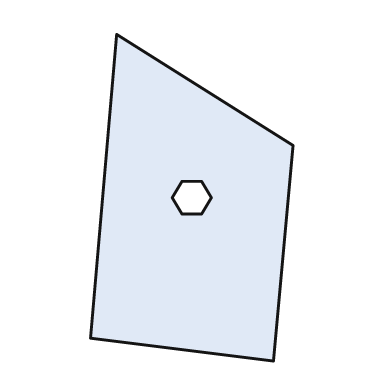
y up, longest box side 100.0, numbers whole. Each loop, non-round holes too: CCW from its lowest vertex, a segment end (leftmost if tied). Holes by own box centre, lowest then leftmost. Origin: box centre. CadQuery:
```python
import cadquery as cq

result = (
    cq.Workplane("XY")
    .moveTo(25.0, -50.0)
    .lineTo(31.0, 16.0)
    .lineTo(-23.0, 50.0)
    .lineTo(-31.0, -43.0)
    .close()
    .moveTo(-3.0, -5.0)
    .lineTo(3.0, -5.0)
    .lineTo(6.0, 0.0)
    .lineTo(3.0, 5.0)
    .lineTo(-3.0, 5.0)
    .lineTo(-6.0, 0.0)
    .close()
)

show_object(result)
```